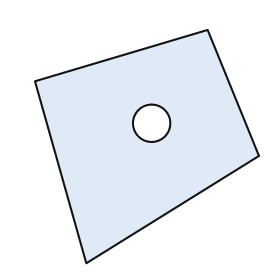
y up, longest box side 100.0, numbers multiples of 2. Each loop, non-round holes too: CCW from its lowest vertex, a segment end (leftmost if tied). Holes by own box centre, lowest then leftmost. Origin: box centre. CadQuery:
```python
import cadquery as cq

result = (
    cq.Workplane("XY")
    .moveTo(-26.0, -50.0)
    .lineTo(48.0, -4.0)
    .lineTo(26.0, 50.0)
    .lineTo(-48.0, 28.0)
    .close()
    .moveTo(2.0, 10.0)
    .circle(8.0)
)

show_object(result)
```